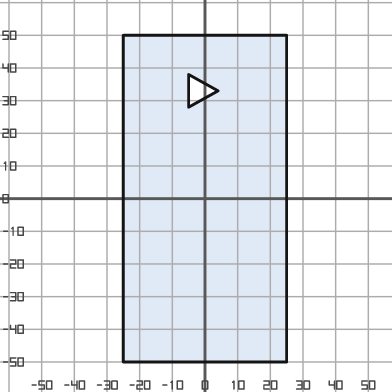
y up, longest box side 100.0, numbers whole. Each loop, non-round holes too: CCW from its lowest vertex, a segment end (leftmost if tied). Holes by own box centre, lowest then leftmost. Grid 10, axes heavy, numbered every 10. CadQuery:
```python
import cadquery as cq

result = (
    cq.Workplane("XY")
    .moveTo(-25.0, -50.0)
    .lineTo(25.0, -50.0)
    .lineTo(25.0, 50.0)
    .lineTo(-25.0, 50.0)
    .close()
    .moveTo(-5.0, 28.0)
    .lineTo(4.0, 33.0)
    .lineTo(-5.0, 38.0)
    .close()
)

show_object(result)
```